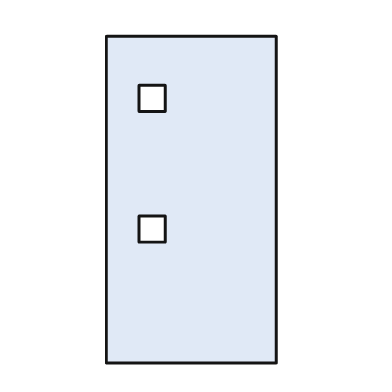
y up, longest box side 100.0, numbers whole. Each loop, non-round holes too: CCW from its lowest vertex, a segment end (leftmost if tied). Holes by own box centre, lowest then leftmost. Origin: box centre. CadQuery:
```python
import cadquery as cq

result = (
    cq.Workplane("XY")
    .moveTo(-26.0, -50.0)
    .lineTo(26.0, -50.0)
    .lineTo(26.0, 50.0)
    .lineTo(-26.0, 50.0)
    .close()
    .moveTo(-16.0, -13.0)
    .lineTo(-8.0, -13.0)
    .lineTo(-8.0, -5.0)
    .lineTo(-16.0, -5.0)
    .close()
    .moveTo(-16.0, 27.0)
    .lineTo(-8.0, 27.0)
    .lineTo(-8.0, 35.0)
    .lineTo(-16.0, 35.0)
    .close()
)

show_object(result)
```